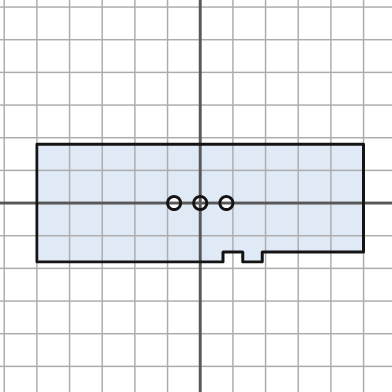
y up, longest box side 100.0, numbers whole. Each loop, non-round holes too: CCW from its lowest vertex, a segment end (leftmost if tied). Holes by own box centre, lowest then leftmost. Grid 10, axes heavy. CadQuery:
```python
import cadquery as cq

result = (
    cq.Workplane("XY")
    .moveTo(-50.0, -18.0)
    .lineTo(7.0, -18.0)
    .lineTo(7.0, -15.0)
    .lineTo(13.0, -15.0)
    .lineTo(13.0, -18.0)
    .lineTo(19.0, -18.0)
    .lineTo(19.0, -15.0)
    .lineTo(50.0, -15.0)
    .lineTo(50.0, 18.0)
    .lineTo(-50.0, 18.0)
    .close()
    .moveTo(-8.0, 0.0)
    .circle(2.0)
    .moveTo(0.0, 0.0)
    .circle(2.0)
    .moveTo(8.0, 0.0)
    .circle(2.0)
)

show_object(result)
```